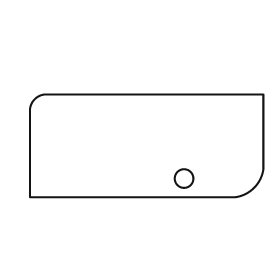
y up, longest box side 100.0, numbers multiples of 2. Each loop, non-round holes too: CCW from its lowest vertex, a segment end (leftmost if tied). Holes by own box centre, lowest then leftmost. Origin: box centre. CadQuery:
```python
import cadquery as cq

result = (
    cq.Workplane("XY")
    .moveTo(-50.0, -22.0)
    .lineTo(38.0, -22.0)
    .threePointArc((46.0, -18.0), (50.0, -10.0))
    .lineTo(50.0, 22.0)
    .lineTo(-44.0, 22.0)
    .threePointArc((-48.0, 20.0), (-50.0, 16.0))
    .close()
    .moveTo(16.0, -14.0)
    .circle(4.0)
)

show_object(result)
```